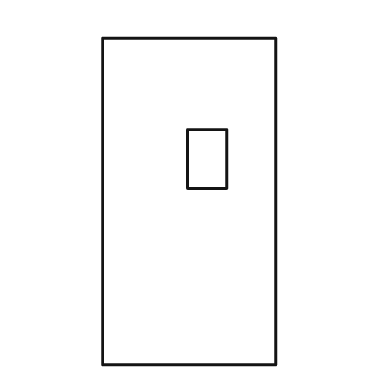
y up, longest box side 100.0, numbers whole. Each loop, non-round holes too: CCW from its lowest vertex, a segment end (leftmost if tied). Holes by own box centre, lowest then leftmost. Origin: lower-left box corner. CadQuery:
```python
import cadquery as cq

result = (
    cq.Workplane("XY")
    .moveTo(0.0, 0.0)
    .lineTo(53.0, 0.0)
    .lineTo(53.0, 100.0)
    .lineTo(0.0, 100.0)
    .close()
    .moveTo(26.0, 54.0)
    .lineTo(38.0, 54.0)
    .lineTo(38.0, 72.0)
    .lineTo(26.0, 72.0)
    .close()
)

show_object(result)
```